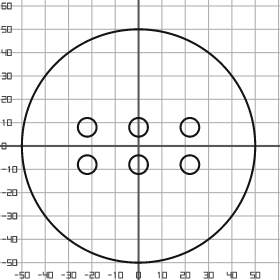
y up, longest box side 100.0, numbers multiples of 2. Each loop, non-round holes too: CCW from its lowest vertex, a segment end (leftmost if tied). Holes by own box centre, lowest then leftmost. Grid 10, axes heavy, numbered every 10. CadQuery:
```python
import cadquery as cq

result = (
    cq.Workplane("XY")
    .moveTo(0.0, 0.0)
    .circle(50.0)
    .moveTo(-22.0, -8.0)
    .circle(4.0)
    .moveTo(0.0, -8.0)
    .circle(4.0)
    .moveTo(22.0, -8.0)
    .circle(4.0)
    .moveTo(-22.0, 8.0)
    .circle(4.0)
    .moveTo(0.0, 8.0)
    .circle(4.0)
    .moveTo(22.0, 8.0)
    .circle(4.0)
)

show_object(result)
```